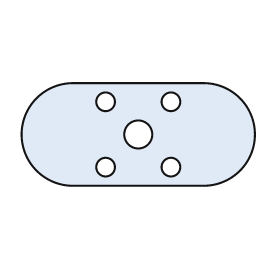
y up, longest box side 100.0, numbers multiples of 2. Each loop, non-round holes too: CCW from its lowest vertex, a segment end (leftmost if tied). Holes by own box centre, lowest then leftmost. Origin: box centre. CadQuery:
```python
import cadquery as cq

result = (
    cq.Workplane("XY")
    .moveTo(-28.0, -22.0)
    .lineTo(28.0, -22.0)
    .threePointArc((50.0, 0.0), (28.0, 22.0))
    .lineTo(-28.0, 22.0)
    .threePointArc((-50.0, 0.0), (-28.0, -22.0))
    .close()
    .moveTo(-14.0, -14.0)
    .circle(4.0)
    .moveTo(14.0, -14.0)
    .circle(4.0)
    .moveTo(0.0, 0.0)
    .circle(6.0)
    .moveTo(-14.0, 14.0)
    .circle(4.0)
    .moveTo(14.0, 14.0)
    .circle(4.0)
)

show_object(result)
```